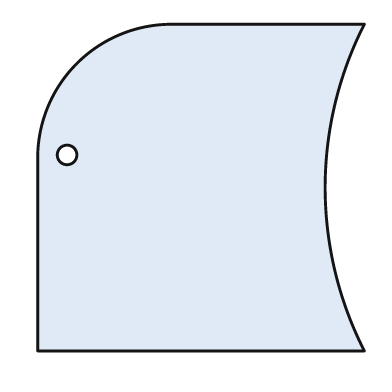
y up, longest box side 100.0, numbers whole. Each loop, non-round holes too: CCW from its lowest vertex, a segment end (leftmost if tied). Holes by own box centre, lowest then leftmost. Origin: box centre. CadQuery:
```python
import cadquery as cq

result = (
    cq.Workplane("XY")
    .moveTo(-50.0, -50.0)
    .lineTo(50.0, -50.0)
    .threePointArc((38.0, 0.0), (50.0, 50.0))
    .lineTo(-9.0, 50.0)
    .threePointArc((-38.0, 38.0), (-50.0, 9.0))
    .close()
    .moveTo(-41.0, 10.0)
    .circle(3.0)
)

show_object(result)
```